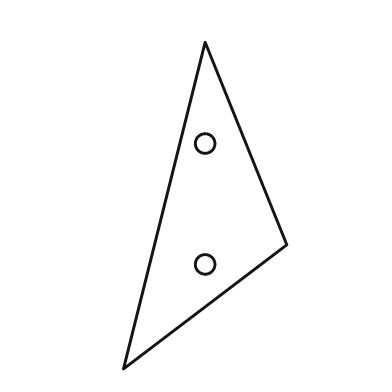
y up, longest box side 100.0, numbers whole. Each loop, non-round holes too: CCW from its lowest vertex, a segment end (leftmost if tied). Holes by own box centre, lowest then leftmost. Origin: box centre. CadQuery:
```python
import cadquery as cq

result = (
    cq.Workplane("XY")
    .moveTo(-25.0, -50.0)
    .lineTo(25.0, -12.0)
    .lineTo(0.0, 50.0)
    .close()
    .moveTo(0.0, -18.0)
    .circle(3.0)
    .moveTo(0.0, 19.0)
    .circle(3.0)
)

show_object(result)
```